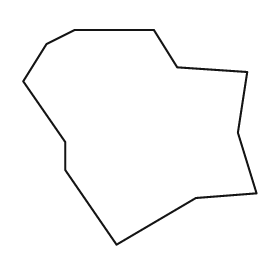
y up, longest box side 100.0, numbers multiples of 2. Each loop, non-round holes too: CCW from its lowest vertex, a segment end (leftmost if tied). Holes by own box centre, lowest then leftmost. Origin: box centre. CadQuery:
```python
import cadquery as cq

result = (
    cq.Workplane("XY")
    .moveTo(-10.0, -46.0)
    .lineTo(24.0, -26.0)
    .lineTo(50.0, -24.0)
    .lineTo(42.0, 2.0)
    .lineTo(46.0, 28.0)
    .lineTo(16.0, 30.0)
    .lineTo(6.0, 46.0)
    .lineTo(-28.0, 46.0)
    .lineTo(-40.0, 40.0)
    .lineTo(-50.0, 24.0)
    .lineTo(-32.0, -2.0)
    .lineTo(-32.0, -14.0)
    .close()
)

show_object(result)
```